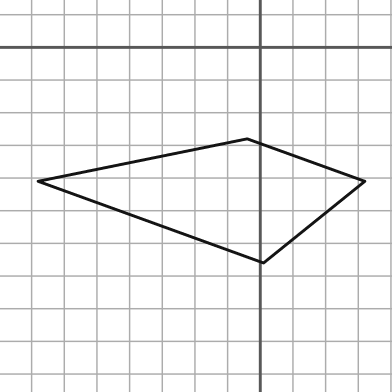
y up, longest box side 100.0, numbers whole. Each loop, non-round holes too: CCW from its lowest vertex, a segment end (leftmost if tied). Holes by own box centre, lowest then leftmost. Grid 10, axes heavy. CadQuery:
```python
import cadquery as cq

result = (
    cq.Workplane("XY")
    .moveTo(1.0, -66.0)
    .lineTo(32.0, -41.0)
    .lineTo(-4.0, -28.0)
    .lineTo(-68.0, -41.0)
    .close()
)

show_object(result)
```